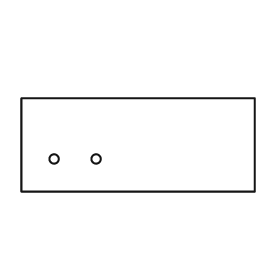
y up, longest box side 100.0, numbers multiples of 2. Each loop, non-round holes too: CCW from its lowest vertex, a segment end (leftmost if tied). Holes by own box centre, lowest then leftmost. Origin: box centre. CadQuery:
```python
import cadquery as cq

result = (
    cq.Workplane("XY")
    .moveTo(-50.0, -20.0)
    .lineTo(50.0, -20.0)
    .lineTo(50.0, 20.0)
    .lineTo(-50.0, 20.0)
    .close()
    .moveTo(-36.0, -6.0)
    .circle(2.0)
    .moveTo(-18.0, -6.0)
    .circle(2.0)
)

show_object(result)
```